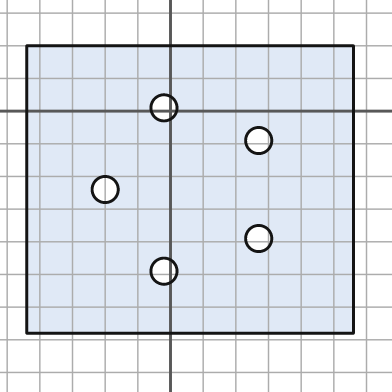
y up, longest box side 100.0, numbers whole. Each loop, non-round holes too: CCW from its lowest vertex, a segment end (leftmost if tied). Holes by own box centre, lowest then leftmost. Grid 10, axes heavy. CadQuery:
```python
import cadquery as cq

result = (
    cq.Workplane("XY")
    .moveTo(-44.0, -68.0)
    .lineTo(56.0, -68.0)
    .lineTo(56.0, 20.0)
    .lineTo(-44.0, 20.0)
    .close()
    .moveTo(-2.0, -49.0)
    .circle(4.0)
    .moveTo(27.0, -39.0)
    .circle(4.0)
    .moveTo(-20.0, -24.0)
    .circle(4.0)
    .moveTo(27.0, -9.0)
    .circle(4.0)
    .moveTo(-2.0, 1.0)
    .circle(4.0)
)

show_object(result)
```